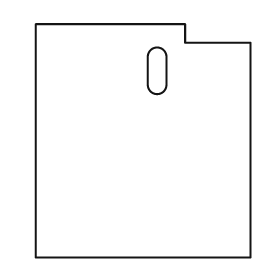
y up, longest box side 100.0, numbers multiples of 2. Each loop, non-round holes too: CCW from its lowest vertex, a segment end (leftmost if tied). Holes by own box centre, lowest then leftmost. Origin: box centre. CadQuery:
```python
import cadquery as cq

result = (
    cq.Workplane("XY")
    .moveTo(-46.0, -50.0)
    .lineTo(46.0, -50.0)
    .lineTo(46.0, 42.0)
    .lineTo(18.0, 42.0)
    .lineTo(18.0, 50.0)
    .lineTo(-46.0, 50.0)
    .close()
    .moveTo(2.0, 24.0)
    .threePointArc((6.0, 20.0), (10.0, 24.0))
    .lineTo(10.0, 36.0)
    .threePointArc((6.0, 40.0), (2.0, 36.0))
    .close()
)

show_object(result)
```